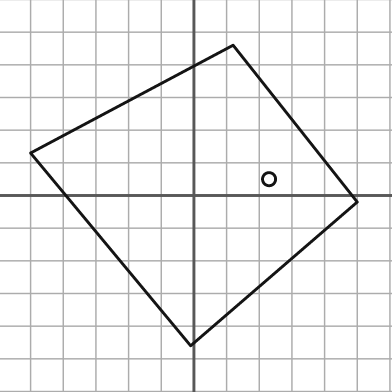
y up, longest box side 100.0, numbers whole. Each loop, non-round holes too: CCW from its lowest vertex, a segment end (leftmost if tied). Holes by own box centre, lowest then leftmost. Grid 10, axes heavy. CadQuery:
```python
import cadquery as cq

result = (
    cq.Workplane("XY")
    .moveTo(-1.0, -46.0)
    .lineTo(50.0, -2.0)
    .lineTo(12.0, 46.0)
    .lineTo(-50.0, 13.0)
    .close()
    .moveTo(23.0, 5.0)
    .circle(2.0)
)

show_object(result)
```